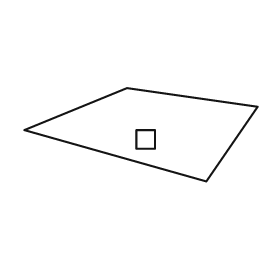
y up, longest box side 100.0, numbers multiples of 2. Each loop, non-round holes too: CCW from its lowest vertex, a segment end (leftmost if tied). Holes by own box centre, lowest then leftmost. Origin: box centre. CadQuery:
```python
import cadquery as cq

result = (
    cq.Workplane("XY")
    .moveTo(28.0, -20.0)
    .lineTo(50.0, 12.0)
    .lineTo(-6.0, 20.0)
    .lineTo(-50.0, 2.0)
    .close()
    .moveTo(-2.0, -6.0)
    .lineTo(6.0, -6.0)
    .lineTo(6.0, 2.0)
    .lineTo(-2.0, 2.0)
    .close()
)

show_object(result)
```